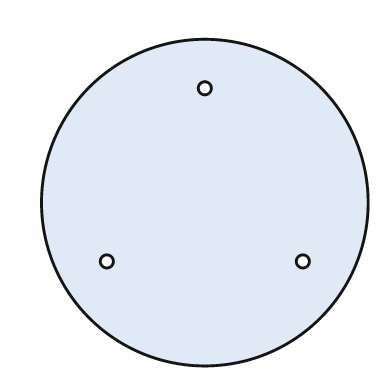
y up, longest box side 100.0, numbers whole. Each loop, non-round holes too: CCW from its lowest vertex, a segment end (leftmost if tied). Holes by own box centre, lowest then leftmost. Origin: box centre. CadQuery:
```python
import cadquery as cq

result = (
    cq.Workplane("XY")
    .moveTo(0.0, 0.0)
    .circle(50.0)
    .moveTo(-30.0, -18.0)
    .circle(2.0)
    .moveTo(30.0, -18.0)
    .circle(2.0)
    .moveTo(0.0, 35.0)
    .circle(2.0)
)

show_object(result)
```